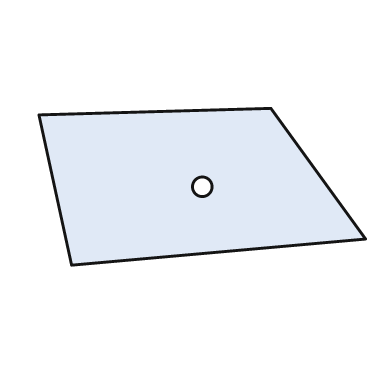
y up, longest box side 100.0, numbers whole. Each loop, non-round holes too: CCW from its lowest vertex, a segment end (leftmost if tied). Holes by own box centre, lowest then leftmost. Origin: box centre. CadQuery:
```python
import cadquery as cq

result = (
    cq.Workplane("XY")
    .moveTo(-40.0, -24.0)
    .lineTo(50.0, -16.0)
    .lineTo(21.0, 24.0)
    .lineTo(-50.0, 22.0)
    .close()
    .moveTo(0.0, 0.0)
    .circle(3.0)
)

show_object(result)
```